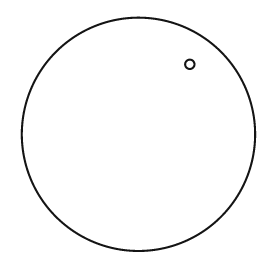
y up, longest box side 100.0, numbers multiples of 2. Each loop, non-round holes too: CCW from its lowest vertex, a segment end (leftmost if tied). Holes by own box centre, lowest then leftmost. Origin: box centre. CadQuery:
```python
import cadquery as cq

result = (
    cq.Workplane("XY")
    .moveTo(0.0, 0.0)
    .circle(50.0)
    .moveTo(22.0, 30.0)
    .circle(2.0)
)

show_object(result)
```